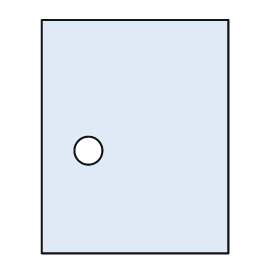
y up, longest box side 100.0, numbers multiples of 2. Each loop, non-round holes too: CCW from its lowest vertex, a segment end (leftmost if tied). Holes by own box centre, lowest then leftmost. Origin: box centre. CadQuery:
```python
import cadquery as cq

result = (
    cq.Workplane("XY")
    .moveTo(-40.0, -50.0)
    .lineTo(40.0, -50.0)
    .lineTo(40.0, 50.0)
    .lineTo(-40.0, 50.0)
    .close()
    .moveTo(-20.0, -6.0)
    .circle(6.0)
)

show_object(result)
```